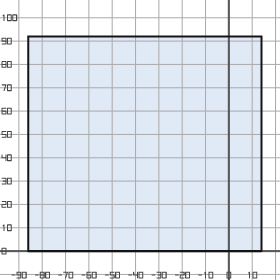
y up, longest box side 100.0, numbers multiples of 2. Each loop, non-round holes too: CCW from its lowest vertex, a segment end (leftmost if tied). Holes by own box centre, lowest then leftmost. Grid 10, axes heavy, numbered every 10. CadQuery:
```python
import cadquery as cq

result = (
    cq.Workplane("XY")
    .moveTo(-86.0, 0.0)
    .lineTo(14.0, 0.0)
    .lineTo(14.0, 92.0)
    .lineTo(-86.0, 92.0)
    .close()
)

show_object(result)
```